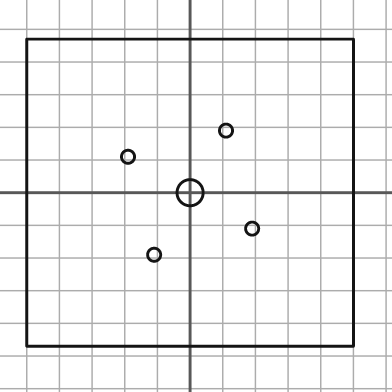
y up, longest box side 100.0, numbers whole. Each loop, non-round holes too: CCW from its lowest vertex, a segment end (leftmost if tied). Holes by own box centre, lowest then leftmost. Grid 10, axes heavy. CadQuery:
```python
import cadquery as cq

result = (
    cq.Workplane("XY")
    .moveTo(-50.0, -47.0)
    .lineTo(50.0, -47.0)
    .lineTo(50.0, 47.0)
    .lineTo(-50.0, 47.0)
    .close()
    .moveTo(-11.0, -19.0)
    .circle(2.0)
    .moveTo(19.0, -11.0)
    .circle(2.0)
    .moveTo(0.0, 0.0)
    .circle(4.0)
    .moveTo(-19.0, 11.0)
    .circle(2.0)
    .moveTo(11.0, 19.0)
    .circle(2.0)
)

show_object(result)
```